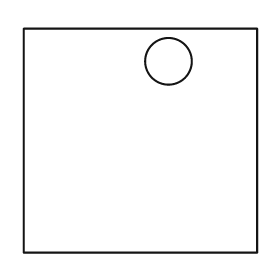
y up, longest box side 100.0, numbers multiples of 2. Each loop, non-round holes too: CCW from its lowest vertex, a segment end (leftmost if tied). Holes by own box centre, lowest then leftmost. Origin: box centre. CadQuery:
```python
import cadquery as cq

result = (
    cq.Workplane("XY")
    .moveTo(-50.0, -48.0)
    .lineTo(50.0, -48.0)
    .lineTo(50.0, 48.0)
    .lineTo(-50.0, 48.0)
    .close()
    .moveTo(12.0, 34.0)
    .circle(10.0)
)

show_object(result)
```